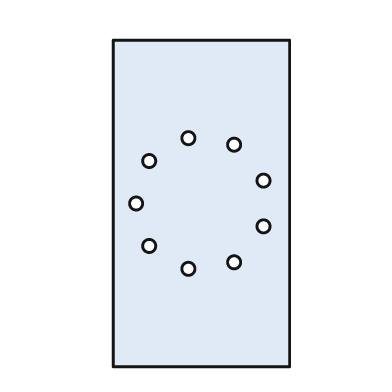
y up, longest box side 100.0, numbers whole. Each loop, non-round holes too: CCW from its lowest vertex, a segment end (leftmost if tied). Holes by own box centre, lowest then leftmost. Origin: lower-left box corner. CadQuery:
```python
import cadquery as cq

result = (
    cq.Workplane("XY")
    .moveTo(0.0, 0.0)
    .lineTo(54.0, 0.0)
    .lineTo(54.0, 100.0)
    .lineTo(0.0, 100.0)
    .close()
    .moveTo(23.0, 30.0)
    .circle(2.0)
    .moveTo(37.0, 32.0)
    .circle(2.0)
    .moveTo(11.0, 37.0)
    .circle(2.0)
    .moveTo(46.0, 43.0)
    .circle(2.0)
    .moveTo(7.0, 50.0)
    .circle(2.0)
    .moveTo(46.0, 57.0)
    .circle(2.0)
    .moveTo(11.0, 63.0)
    .circle(2.0)
    .moveTo(37.0, 68.0)
    .circle(2.0)
    .moveTo(23.0, 70.0)
    .circle(2.0)
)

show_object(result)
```